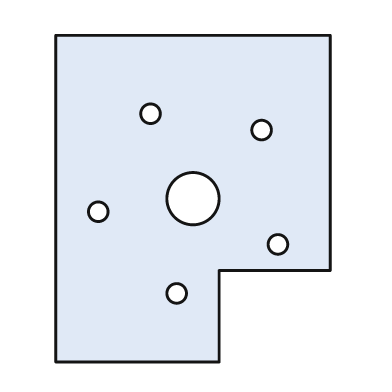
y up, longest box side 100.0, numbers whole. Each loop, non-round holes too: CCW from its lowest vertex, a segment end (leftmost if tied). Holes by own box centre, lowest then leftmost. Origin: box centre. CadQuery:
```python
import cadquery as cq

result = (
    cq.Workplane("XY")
    .moveTo(-42.0, -50.0)
    .lineTo(8.0, -50.0)
    .lineTo(8.0, -22.0)
    .lineTo(42.0, -22.0)
    .lineTo(42.0, 50.0)
    .lineTo(-42.0, 50.0)
    .close()
    .moveTo(-5.0, -29.0)
    .circle(3.0)
    .moveTo(26.0, -14.0)
    .circle(3.0)
    .moveTo(-29.0, -4.0)
    .circle(3.0)
    .moveTo(0.0, 0.0)
    .circle(8.0)
    .moveTo(21.0, 21.0)
    .circle(3.0)
    .moveTo(-13.0, 26.0)
    .circle(3.0)
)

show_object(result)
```